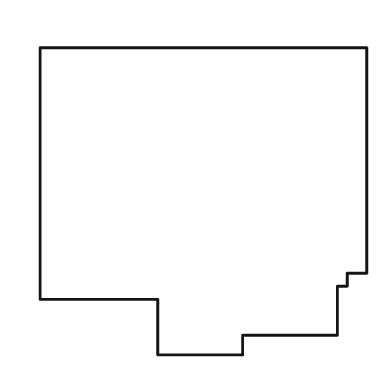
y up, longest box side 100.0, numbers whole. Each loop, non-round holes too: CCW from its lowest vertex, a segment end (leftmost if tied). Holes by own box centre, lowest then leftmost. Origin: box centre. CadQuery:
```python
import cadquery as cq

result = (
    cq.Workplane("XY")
    .moveTo(-14.0, -47.0)
    .lineTo(12.0, -47.0)
    .lineTo(12.0, -41.0)
    .lineTo(41.0, -41.0)
    .lineTo(41.0, -26.0)
    .lineTo(44.0, -26.0)
    .lineTo(44.0, -22.0)
    .lineTo(50.0, -22.0)
    .lineTo(50.0, 47.0)
    .lineTo(-50.0, 47.0)
    .lineTo(-50.0, -30.0)
    .lineTo(-14.0, -30.0)
    .close()
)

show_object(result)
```